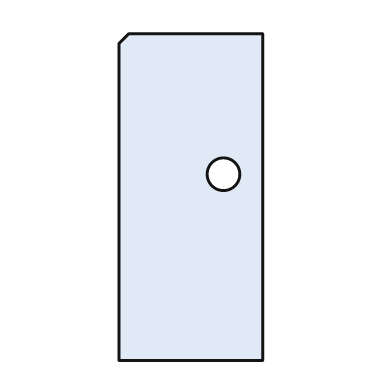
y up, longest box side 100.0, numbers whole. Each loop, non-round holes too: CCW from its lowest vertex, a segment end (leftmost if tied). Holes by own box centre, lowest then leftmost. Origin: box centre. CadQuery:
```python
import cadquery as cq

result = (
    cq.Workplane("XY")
    .moveTo(-22.0, -50.0)
    .lineTo(22.0, -50.0)
    .lineTo(22.0, 50.0)
    .lineTo(-19.0, 50.0)
    .lineTo(-22.0, 47.0)
    .close()
    .moveTo(10.0, 7.0)
    .circle(5.0)
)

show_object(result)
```